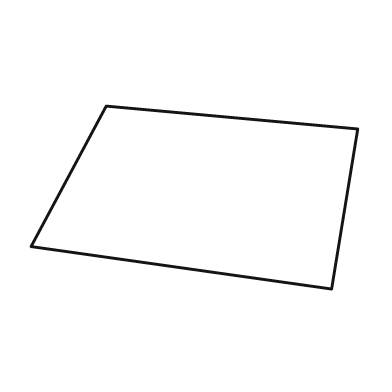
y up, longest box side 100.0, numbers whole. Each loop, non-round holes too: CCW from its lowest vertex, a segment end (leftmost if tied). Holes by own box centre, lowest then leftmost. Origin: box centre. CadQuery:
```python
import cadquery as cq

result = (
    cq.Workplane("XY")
    .moveTo(42.0, -28.0)
    .lineTo(50.0, 21.0)
    .lineTo(-27.0, 28.0)
    .lineTo(-50.0, -15.0)
    .close()
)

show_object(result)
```